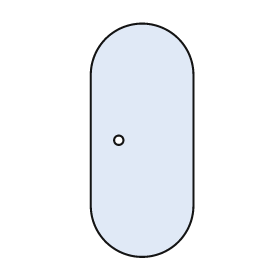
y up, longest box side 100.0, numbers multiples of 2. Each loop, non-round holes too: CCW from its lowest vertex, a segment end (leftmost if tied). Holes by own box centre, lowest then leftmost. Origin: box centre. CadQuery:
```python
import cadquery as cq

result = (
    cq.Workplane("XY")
    .moveTo(-22.0, -28.0)
    .threePointArc((0.0, -50.0), (22.0, -28.0))
    .lineTo(22.0, 28.0)
    .threePointArc((0.0, 50.0), (-22.0, 28.0))
    .close()
    .moveTo(-10.0, 0.0)
    .circle(2.0)
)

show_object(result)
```